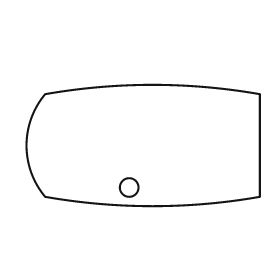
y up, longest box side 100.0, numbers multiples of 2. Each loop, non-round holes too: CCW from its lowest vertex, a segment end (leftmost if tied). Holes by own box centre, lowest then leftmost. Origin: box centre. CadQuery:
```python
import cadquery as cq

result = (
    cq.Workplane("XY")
    .moveTo(-42.0, -22.0)
    .threePointArc((4.0, -26.0), (50.0, -22.0))
    .lineTo(50.0, 22.0)
    .threePointArc((4.0, 26.0), (-42.0, 22.0))
    .threePointArc((-50.0, 0.0), (-42.0, -22.0))
    .close()
    .moveTo(-6.0, -18.0)
    .circle(4.0)
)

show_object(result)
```